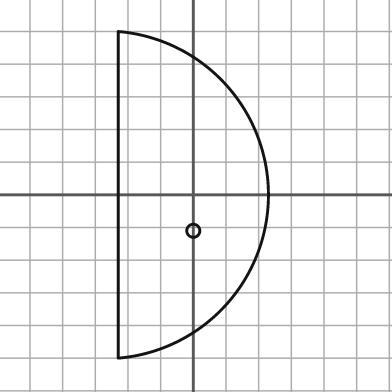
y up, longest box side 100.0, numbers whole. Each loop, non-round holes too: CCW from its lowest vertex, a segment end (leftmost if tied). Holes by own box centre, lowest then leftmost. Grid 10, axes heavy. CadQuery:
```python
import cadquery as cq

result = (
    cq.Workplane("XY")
    .moveTo(-23.0, -50.0)
    .threePointArc((23.0, 0.0), (-23.0, 50.0))
    .close()
    .moveTo(0.0, -11.0)
    .circle(2.0)
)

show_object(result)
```